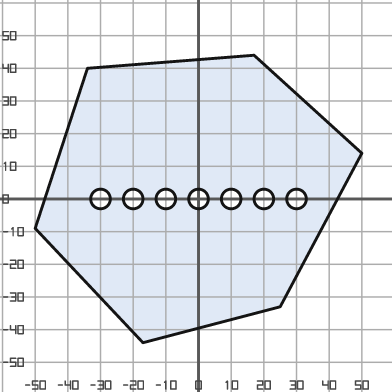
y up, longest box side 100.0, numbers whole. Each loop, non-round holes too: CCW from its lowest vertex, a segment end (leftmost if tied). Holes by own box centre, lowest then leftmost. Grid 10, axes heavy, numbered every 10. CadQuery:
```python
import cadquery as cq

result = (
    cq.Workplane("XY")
    .moveTo(-17.0, -44.0)
    .lineTo(25.0, -33.0)
    .lineTo(50.0, 14.0)
    .lineTo(17.0, 44.0)
    .lineTo(-34.0, 40.0)
    .lineTo(-50.0, -9.0)
    .close()
    .moveTo(-30.0, 0.0)
    .circle(3.0)
    .moveTo(-20.0, 0.0)
    .circle(3.0)
    .moveTo(-10.0, 0.0)
    .circle(3.0)
    .moveTo(0.0, 0.0)
    .circle(3.0)
    .moveTo(10.0, 0.0)
    .circle(3.0)
    .moveTo(20.0, 0.0)
    .circle(3.0)
    .moveTo(30.0, 0.0)
    .circle(3.0)
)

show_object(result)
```